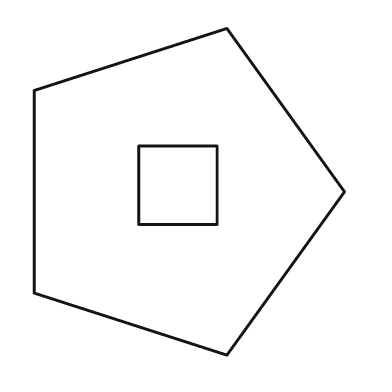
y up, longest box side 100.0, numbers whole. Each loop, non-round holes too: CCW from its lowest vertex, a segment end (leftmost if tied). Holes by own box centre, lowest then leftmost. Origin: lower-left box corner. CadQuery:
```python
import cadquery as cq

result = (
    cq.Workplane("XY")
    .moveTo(59.0, 0.0)
    .lineTo(95.0, 50.0)
    .lineTo(59.0, 100.0)
    .lineTo(0.0, 81.0)
    .lineTo(0.0, 19.0)
    .close()
    .moveTo(32.0, 40.0)
    .lineTo(56.0, 40.0)
    .lineTo(56.0, 64.0)
    .lineTo(32.0, 64.0)
    .close()
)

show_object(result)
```